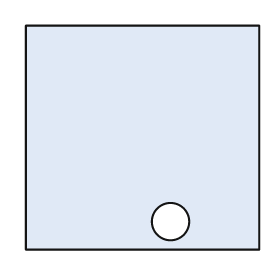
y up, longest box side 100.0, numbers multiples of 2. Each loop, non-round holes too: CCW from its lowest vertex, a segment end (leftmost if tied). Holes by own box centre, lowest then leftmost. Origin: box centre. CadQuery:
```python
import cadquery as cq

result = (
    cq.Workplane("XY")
    .moveTo(-50.0, -48.0)
    .lineTo(50.0, -48.0)
    .lineTo(50.0, 48.0)
    .lineTo(-50.0, 48.0)
    .close()
    .moveTo(12.0, -36.0)
    .circle(8.0)
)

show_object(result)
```